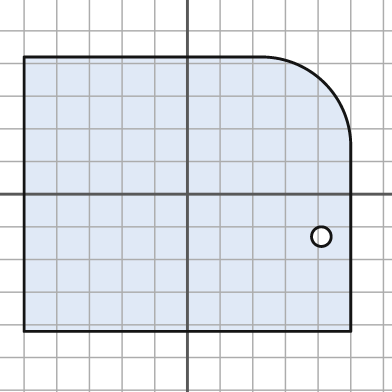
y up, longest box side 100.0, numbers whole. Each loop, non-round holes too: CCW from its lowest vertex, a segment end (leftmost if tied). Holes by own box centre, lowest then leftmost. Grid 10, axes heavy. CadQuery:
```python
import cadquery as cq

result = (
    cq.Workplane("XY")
    .moveTo(-50.0, -42.0)
    .lineTo(50.0, -42.0)
    .lineTo(50.0, 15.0)
    .threePointArc((42.0, 34.0), (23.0, 42.0))
    .lineTo(-50.0, 42.0)
    .close()
    .moveTo(41.0, -13.0)
    .circle(3.0)
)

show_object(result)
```